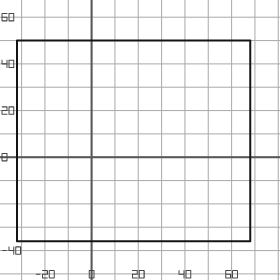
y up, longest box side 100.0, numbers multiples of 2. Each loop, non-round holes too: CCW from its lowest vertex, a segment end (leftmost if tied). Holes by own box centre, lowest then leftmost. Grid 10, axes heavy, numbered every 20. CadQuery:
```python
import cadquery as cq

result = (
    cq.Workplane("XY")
    .moveTo(-32.0, -36.0)
    .lineTo(68.0, -36.0)
    .lineTo(68.0, 50.0)
    .lineTo(-32.0, 50.0)
    .close()
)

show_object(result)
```